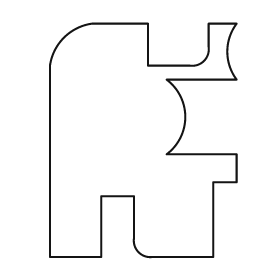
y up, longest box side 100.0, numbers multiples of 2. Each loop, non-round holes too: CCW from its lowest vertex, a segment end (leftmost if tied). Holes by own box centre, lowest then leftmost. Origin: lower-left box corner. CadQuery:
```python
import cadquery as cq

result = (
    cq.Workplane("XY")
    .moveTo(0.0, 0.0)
    .lineTo(22.0, 0.0)
    .lineTo(22.0, 26.0)
    .lineTo(36.0, 26.0)
    .lineTo(36.0, 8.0)
    .threePointArc((38.0, 2.0), (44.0, 0.0))
    .lineTo(70.0, 0.0)
    .lineTo(70.0, 32.0)
    .lineTo(80.0, 32.0)
    .lineTo(80.0, 44.0)
    .lineTo(50.0, 44.0)
    .threePointArc((58.0, 60.0), (50.0, 76.0))
    .lineTo(80.0, 76.0)
    .threePointArc((76.0, 88.0), (80.0, 100.0))
    .lineTo(68.0, 100.0)
    .lineTo(68.0, 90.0)
    .threePointArc((66.0, 84.0), (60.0, 82.0))
    .lineTo(42.0, 82.0)
    .lineTo(42.0, 100.0)
    .lineTo(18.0, 100.0)
    .threePointArc((6.0, 94.0), (0.0, 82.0))
    .close()
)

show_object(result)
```